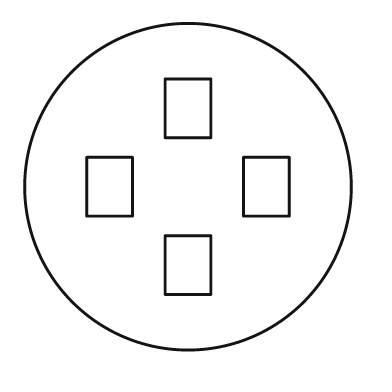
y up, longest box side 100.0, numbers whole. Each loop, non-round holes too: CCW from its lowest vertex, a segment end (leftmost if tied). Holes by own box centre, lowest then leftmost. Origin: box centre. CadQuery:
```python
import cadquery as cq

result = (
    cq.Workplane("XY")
    .moveTo(0.0, 0.0)
    .circle(50.0)
    .moveTo(-7.0, -33.0)
    .lineTo(7.0, -33.0)
    .lineTo(7.0, -15.0)
    .lineTo(-7.0, -15.0)
    .close()
    .moveTo(-31.0, -9.0)
    .lineTo(-17.0, -9.0)
    .lineTo(-17.0, 9.0)
    .lineTo(-31.0, 9.0)
    .close()
    .moveTo(17.0, -9.0)
    .lineTo(31.0, -9.0)
    .lineTo(31.0, 9.0)
    .lineTo(17.0, 9.0)
    .close()
    .moveTo(-7.0, 15.0)
    .lineTo(7.0, 15.0)
    .lineTo(7.0, 33.0)
    .lineTo(-7.0, 33.0)
    .close()
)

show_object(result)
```